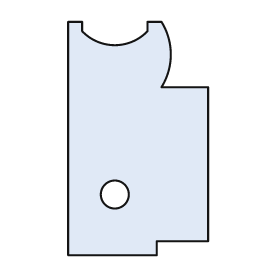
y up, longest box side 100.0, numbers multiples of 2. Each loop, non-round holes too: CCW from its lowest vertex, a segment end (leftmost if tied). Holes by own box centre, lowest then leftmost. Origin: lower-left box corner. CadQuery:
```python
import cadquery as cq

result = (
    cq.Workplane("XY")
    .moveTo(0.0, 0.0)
    .lineTo(38.0, 0.0)
    .lineTo(38.0, 6.0)
    .lineTo(60.0, 6.0)
    .lineTo(60.0, 72.0)
    .lineTo(40.0, 72.0)
    .threePointArc((44.0, 86.0), (40.0, 100.0))
    .lineTo(34.0, 100.0)
    .lineTo(34.0, 96.0)
    .threePointArc((20.0, 90.0), (6.0, 96.0))
    .lineTo(6.0, 100.0)
    .lineTo(0.0, 100.0)
    .close()
    .moveTo(20.0, 26.0)
    .circle(6.0)
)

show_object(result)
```